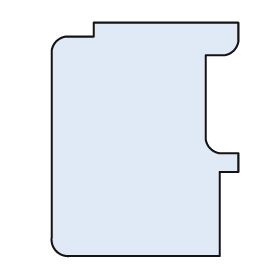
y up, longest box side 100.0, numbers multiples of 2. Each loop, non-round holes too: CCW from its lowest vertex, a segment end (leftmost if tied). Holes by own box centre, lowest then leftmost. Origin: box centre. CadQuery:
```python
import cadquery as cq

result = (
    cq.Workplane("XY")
    .moveTo(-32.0, -50.0)
    .lineTo(32.0, -50.0)
    .lineTo(32.0, -14.0)
    .lineTo(40.0, -14.0)
    .lineTo(40.0, -6.0)
    .lineTo(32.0, -6.0)
    .threePointArc((28.0, -4.0), (26.0, 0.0))
    .lineTo(26.0, 36.0)
    .lineTo(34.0, 36.0)
    .threePointArc((38.0, 38.0), (40.0, 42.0))
    .lineTo(40.0, 50.0)
    .lineTo(-22.0, 50.0)
    .lineTo(-22.0, 44.0)
    .lineTo(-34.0, 44.0)
    .threePointArc((-38.0, 42.0), (-40.0, 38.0))
    .lineTo(-40.0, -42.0)
    .threePointArc((-38.0, -48.0), (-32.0, -50.0))
    .close()
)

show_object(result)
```